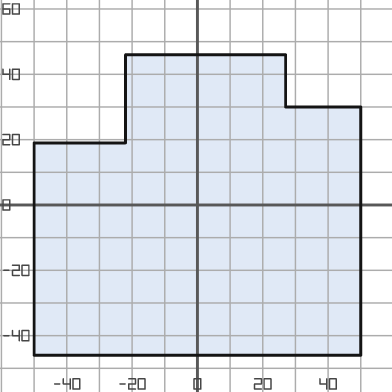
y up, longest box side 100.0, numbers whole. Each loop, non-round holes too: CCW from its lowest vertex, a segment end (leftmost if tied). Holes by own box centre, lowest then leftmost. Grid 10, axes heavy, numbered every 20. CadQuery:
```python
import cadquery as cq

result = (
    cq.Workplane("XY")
    .moveTo(-50.0, -46.0)
    .lineTo(50.0, -46.0)
    .lineTo(50.0, 30.0)
    .lineTo(27.0, 30.0)
    .lineTo(27.0, 46.0)
    .lineTo(-22.0, 46.0)
    .lineTo(-22.0, 19.0)
    .lineTo(-50.0, 19.0)
    .close()
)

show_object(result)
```